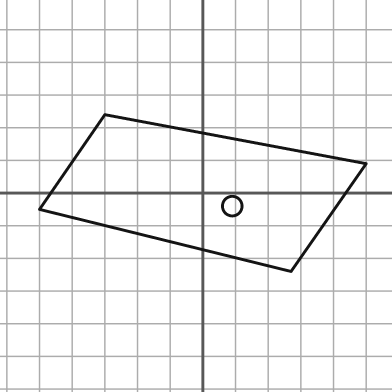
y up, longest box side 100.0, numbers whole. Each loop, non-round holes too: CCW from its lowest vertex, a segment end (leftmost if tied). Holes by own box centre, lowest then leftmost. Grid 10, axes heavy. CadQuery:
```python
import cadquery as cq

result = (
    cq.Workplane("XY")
    .moveTo(27.0, -24.0)
    .lineTo(50.0, 9.0)
    .lineTo(-30.0, 24.0)
    .lineTo(-50.0, -5.0)
    .close()
    .moveTo(9.0, -4.0)
    .circle(3.0)
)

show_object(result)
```